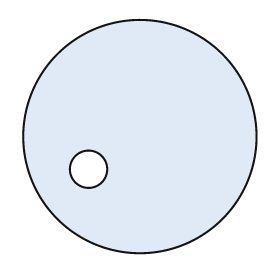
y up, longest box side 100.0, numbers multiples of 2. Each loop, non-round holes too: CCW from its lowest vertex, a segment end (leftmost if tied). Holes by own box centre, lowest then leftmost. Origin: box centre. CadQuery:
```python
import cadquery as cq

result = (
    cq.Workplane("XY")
    .moveTo(0.0, 0.0)
    .circle(50.0)
    .moveTo(-22.0, -14.0)
    .circle(8.0)
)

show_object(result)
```